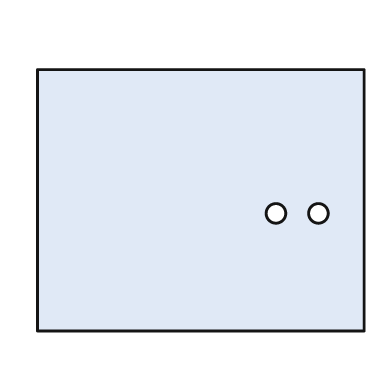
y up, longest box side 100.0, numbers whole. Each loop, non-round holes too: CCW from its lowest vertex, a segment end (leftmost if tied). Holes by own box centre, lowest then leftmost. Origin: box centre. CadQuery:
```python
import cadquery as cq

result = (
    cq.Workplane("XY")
    .moveTo(-50.0, -40.0)
    .lineTo(50.0, -40.0)
    .lineTo(50.0, 40.0)
    .lineTo(-50.0, 40.0)
    .close()
    .moveTo(23.0, -4.0)
    .circle(3.0)
    .moveTo(36.0, -4.0)
    .circle(3.0)
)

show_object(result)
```